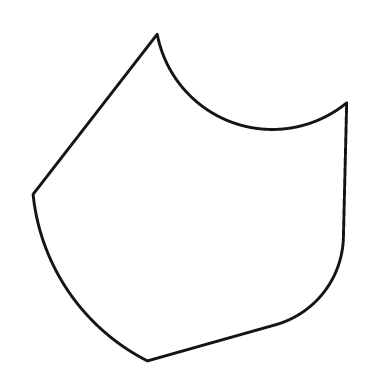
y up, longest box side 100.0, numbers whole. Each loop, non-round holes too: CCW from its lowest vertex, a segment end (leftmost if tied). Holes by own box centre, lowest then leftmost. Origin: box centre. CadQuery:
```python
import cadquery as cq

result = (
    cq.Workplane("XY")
    .moveTo(-13.0, -50.0)
    .lineTo(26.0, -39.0)
    .threePointArc((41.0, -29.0), (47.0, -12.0))
    .lineTo(48.0, 29.0)
    .threePointArc((13.0, 23.0), (-10.0, 50.0))
    .lineTo(-48.0, 1.0)
    .threePointArc((-37.0, -29.0), (-13.0, -50.0))
    .close()
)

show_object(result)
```